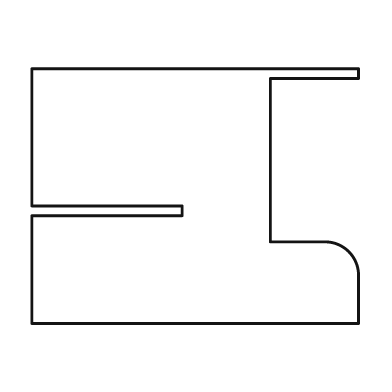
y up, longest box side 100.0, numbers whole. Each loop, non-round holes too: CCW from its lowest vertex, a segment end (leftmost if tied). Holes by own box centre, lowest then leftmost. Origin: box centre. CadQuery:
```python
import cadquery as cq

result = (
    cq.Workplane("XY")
    .moveTo(-50.0, -39.0)
    .lineTo(50.0, -39.0)
    .lineTo(50.0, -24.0)
    .threePointArc((47.0, -17.0), (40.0, -14.0))
    .lineTo(23.0, -14.0)
    .lineTo(23.0, 36.0)
    .lineTo(50.0, 36.0)
    .lineTo(50.0, 39.0)
    .lineTo(-50.0, 39.0)
    .lineTo(-50.0, -3.0)
    .lineTo(-4.0, -3.0)
    .lineTo(-4.0, -6.0)
    .lineTo(-50.0, -6.0)
    .close()
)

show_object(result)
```